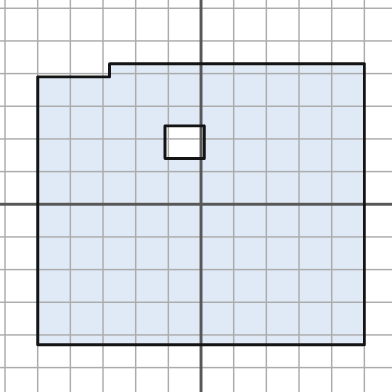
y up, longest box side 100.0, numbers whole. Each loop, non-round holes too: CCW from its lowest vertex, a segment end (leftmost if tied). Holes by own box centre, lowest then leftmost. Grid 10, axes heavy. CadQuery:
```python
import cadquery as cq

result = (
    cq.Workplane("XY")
    .moveTo(-50.0, -43.0)
    .lineTo(50.0, -43.0)
    .lineTo(50.0, 43.0)
    .lineTo(-28.0, 43.0)
    .lineTo(-28.0, 39.0)
    .lineTo(-50.0, 39.0)
    .close()
    .moveTo(-11.0, 14.0)
    .lineTo(1.0, 14.0)
    .lineTo(1.0, 24.0)
    .lineTo(-11.0, 24.0)
    .close()
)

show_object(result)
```